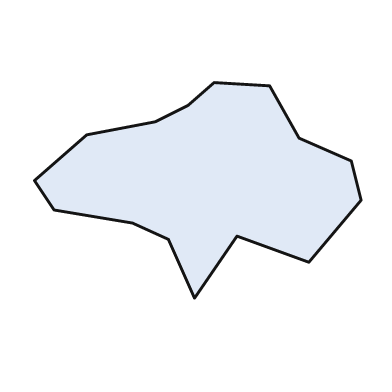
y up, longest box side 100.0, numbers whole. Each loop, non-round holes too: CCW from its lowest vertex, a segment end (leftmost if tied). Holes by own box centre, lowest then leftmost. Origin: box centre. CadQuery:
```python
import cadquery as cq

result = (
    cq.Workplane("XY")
    .moveTo(-1.0, -33.0)
    .lineTo(12.0, -14.0)
    .lineTo(34.0, -22.0)
    .lineTo(50.0, -3.0)
    .lineTo(47.0, 9.0)
    .lineTo(31.0, 16.0)
    .lineTo(22.0, 32.0)
    .lineTo(5.0, 33.0)
    .lineTo(-3.0, 26.0)
    .lineTo(-13.0, 21.0)
    .lineTo(-34.0, 17.0)
    .lineTo(-50.0, 3.0)
    .lineTo(-44.0, -6.0)
    .lineTo(-20.0, -10.0)
    .lineTo(-9.0, -15.0)
    .close()
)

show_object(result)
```